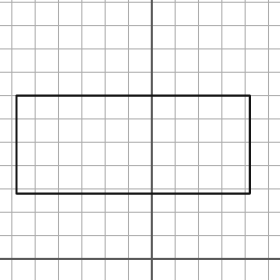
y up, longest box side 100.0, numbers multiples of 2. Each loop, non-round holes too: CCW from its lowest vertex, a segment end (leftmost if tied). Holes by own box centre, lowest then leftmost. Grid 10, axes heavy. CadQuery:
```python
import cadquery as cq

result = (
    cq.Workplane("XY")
    .moveTo(-58.0, 28.0)
    .lineTo(42.0, 28.0)
    .lineTo(42.0, 70.0)
    .lineTo(-58.0, 70.0)
    .close()
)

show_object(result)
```